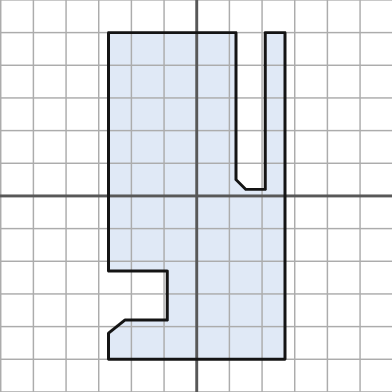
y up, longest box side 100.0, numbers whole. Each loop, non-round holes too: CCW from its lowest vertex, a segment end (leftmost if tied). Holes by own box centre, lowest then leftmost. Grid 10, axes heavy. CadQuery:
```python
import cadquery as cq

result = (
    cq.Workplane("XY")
    .moveTo(-27.0, -50.0)
    .lineTo(27.0, -50.0)
    .lineTo(27.0, 50.0)
    .lineTo(21.0, 50.0)
    .lineTo(21.0, 2.0)
    .lineTo(15.0, 2.0)
    .lineTo(12.0, 5.0)
    .lineTo(12.0, 50.0)
    .lineTo(-27.0, 50.0)
    .lineTo(-27.0, -23.0)
    .lineTo(-9.0, -23.0)
    .lineTo(-9.0, -38.0)
    .lineTo(-22.0, -38.0)
    .lineTo(-27.0, -42.0)
    .close()
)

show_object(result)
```